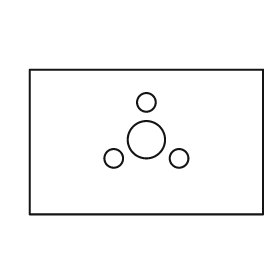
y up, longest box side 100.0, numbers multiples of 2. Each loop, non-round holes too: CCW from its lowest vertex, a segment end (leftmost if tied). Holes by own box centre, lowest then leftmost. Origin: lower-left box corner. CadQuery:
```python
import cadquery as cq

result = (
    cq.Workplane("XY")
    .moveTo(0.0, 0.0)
    .lineTo(100.0, 0.0)
    .lineTo(100.0, 62.0)
    .lineTo(0.0, 62.0)
    .close()
    .moveTo(36.0, 24.0)
    .circle(4.0)
    .moveTo(64.0, 24.0)
    .circle(4.0)
    .moveTo(50.0, 32.0)
    .circle(8.0)
    .moveTo(50.0, 48.0)
    .circle(4.0)
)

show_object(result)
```